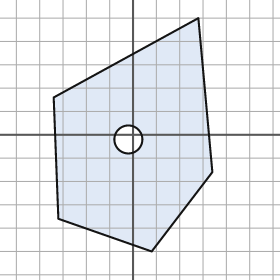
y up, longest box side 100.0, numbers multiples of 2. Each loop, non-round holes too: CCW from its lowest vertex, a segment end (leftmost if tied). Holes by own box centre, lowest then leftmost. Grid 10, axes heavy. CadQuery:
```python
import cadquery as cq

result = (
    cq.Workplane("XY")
    .moveTo(8.0, -50.0)
    .lineTo(34.0, -16.0)
    .lineTo(28.0, 50.0)
    .lineTo(-34.0, 16.0)
    .lineTo(-32.0, -36.0)
    .close()
    .moveTo(-2.0, -2.0)
    .circle(6.0)
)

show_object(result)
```